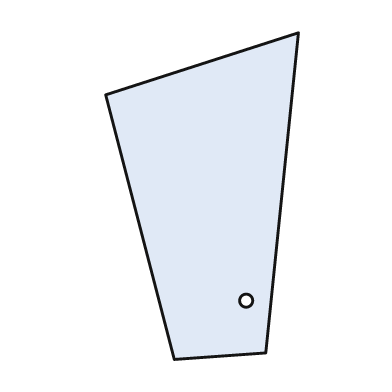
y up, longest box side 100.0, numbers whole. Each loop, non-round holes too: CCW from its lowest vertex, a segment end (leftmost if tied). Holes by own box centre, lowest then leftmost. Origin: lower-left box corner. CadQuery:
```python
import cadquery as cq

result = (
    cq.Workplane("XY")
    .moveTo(21.0, 0.0)
    .lineTo(49.0, 2.0)
    .lineTo(59.0, 100.0)
    .lineTo(0.0, 81.0)
    .close()
    .moveTo(43.0, 18.0)
    .circle(2.0)
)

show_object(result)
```